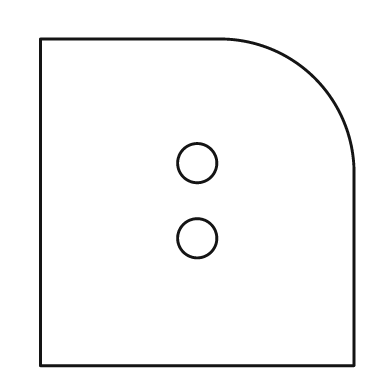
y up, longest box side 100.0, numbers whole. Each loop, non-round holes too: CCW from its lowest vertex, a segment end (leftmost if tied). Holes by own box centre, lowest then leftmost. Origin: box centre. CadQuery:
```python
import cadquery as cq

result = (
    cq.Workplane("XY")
    .moveTo(-48.0, -50.0)
    .lineTo(48.0, -50.0)
    .lineTo(48.0, 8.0)
    .threePointArc((36.0, 38.0), (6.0, 50.0))
    .lineTo(-48.0, 50.0)
    .close()
    .moveTo(0.0, -11.0)
    .circle(6.0)
    .moveTo(0.0, 12.0)
    .circle(6.0)
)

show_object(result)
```